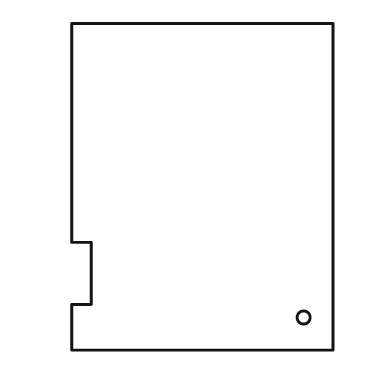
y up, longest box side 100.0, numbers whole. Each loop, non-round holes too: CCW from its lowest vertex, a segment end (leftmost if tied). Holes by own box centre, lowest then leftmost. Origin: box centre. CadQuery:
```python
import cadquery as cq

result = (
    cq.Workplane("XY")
    .moveTo(-40.0, -50.0)
    .lineTo(40.0, -50.0)
    .lineTo(40.0, 50.0)
    .lineTo(-40.0, 50.0)
    .lineTo(-40.0, -17.0)
    .lineTo(-34.0, -17.0)
    .lineTo(-34.0, -36.0)
    .lineTo(-40.0, -36.0)
    .close()
    .moveTo(31.0, -40.0)
    .circle(2.0)
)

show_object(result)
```